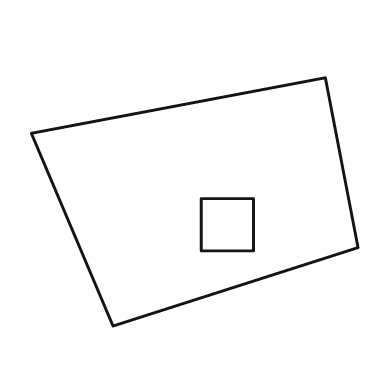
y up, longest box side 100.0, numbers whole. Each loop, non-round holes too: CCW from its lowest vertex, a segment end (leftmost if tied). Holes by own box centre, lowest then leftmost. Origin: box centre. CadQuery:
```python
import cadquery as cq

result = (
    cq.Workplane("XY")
    .moveTo(-25.0, -38.0)
    .lineTo(50.0, -14.0)
    .lineTo(40.0, 38.0)
    .lineTo(-50.0, 21.0)
    .close()
    .moveTo(2.0, -15.0)
    .lineTo(18.0, -15.0)
    .lineTo(18.0, 1.0)
    .lineTo(2.0, 1.0)
    .close()
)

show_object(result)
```